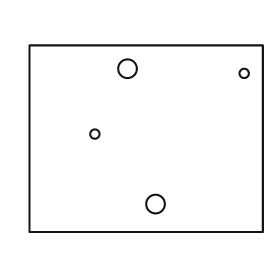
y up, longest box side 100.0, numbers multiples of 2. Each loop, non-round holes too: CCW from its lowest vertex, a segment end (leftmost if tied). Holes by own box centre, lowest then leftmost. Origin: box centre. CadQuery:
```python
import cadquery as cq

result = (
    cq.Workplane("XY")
    .moveTo(-50.0, -40.0)
    .lineTo(50.0, -40.0)
    .lineTo(50.0, 40.0)
    .lineTo(-50.0, 40.0)
    .close()
    .moveTo(4.0, -28.0)
    .circle(4.0)
    .moveTo(-22.0, 2.0)
    .circle(2.0)
    .moveTo(42.0, 28.0)
    .circle(2.0)
    .moveTo(-8.0, 30.0)
    .circle(4.0)
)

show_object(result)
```